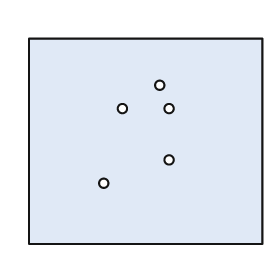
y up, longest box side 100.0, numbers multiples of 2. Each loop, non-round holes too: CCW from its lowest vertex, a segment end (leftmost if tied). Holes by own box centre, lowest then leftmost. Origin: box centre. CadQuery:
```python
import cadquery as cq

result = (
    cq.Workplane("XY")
    .moveTo(-50.0, -44.0)
    .lineTo(50.0, -44.0)
    .lineTo(50.0, 44.0)
    .lineTo(-50.0, 44.0)
    .close()
    .moveTo(-18.0, -18.0)
    .circle(2.0)
    .moveTo(10.0, -8.0)
    .circle(2.0)
    .moveTo(-10.0, 14.0)
    .circle(2.0)
    .moveTo(10.0, 14.0)
    .circle(2.0)
    .moveTo(6.0, 24.0)
    .circle(2.0)
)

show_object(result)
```